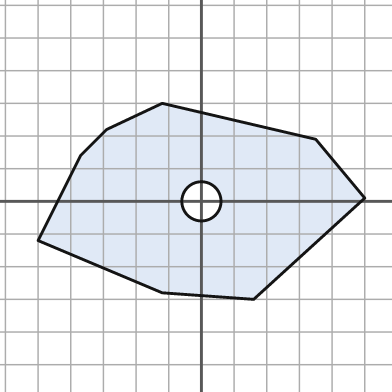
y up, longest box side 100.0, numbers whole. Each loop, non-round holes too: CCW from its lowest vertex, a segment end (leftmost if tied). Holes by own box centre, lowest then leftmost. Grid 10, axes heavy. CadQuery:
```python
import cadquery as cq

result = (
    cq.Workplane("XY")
    .moveTo(16.0, -30.0)
    .lineTo(50.0, 1.0)
    .lineTo(35.0, 19.0)
    .lineTo(-12.0, 30.0)
    .lineTo(-29.0, 22.0)
    .lineTo(-37.0, 14.0)
    .lineTo(-50.0, -12.0)
    .lineTo(-12.0, -28.0)
    .close()
    .moveTo(0.0, 0.0)
    .circle(6.0)
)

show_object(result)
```